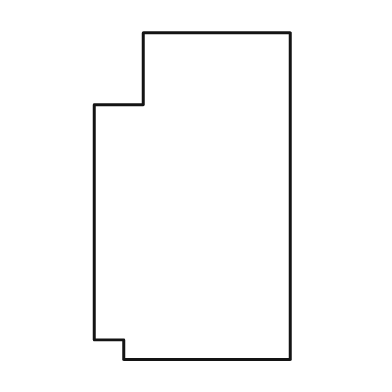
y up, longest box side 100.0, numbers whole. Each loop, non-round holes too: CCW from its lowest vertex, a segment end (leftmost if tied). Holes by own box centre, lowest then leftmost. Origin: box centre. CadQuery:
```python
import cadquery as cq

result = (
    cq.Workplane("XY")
    .moveTo(-21.0, -50.0)
    .lineTo(30.0, -50.0)
    .lineTo(30.0, 50.0)
    .lineTo(-15.0, 50.0)
    .lineTo(-15.0, 28.0)
    .lineTo(-30.0, 28.0)
    .lineTo(-30.0, -44.0)
    .lineTo(-21.0, -44.0)
    .close()
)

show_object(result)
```